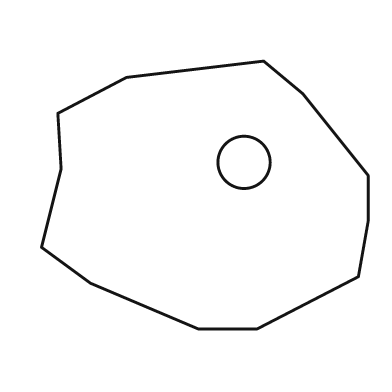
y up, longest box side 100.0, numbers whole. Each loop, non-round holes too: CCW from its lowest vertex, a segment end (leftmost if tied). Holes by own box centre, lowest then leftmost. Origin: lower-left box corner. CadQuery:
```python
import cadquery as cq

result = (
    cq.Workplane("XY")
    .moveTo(48.0, 0.0)
    .lineTo(66.0, 0.0)
    .lineTo(97.0, 16.0)
    .lineTo(100.0, 33.0)
    .lineTo(100.0, 47.0)
    .lineTo(80.0, 72.0)
    .lineTo(68.0, 82.0)
    .lineTo(26.0, 77.0)
    .lineTo(5.0, 66.0)
    .lineTo(6.0, 49.0)
    .lineTo(0.0, 25.0)
    .lineTo(15.0, 14.0)
    .close()
    .moveTo(62.0, 51.0)
    .circle(8.0)
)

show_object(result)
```